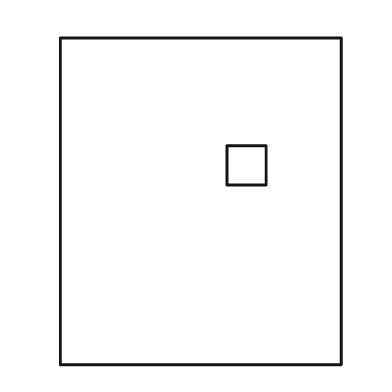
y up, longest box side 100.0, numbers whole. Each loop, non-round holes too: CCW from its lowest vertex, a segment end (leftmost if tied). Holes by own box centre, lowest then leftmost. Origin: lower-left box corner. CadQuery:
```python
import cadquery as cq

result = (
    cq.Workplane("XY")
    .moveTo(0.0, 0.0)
    .lineTo(86.0, 0.0)
    .lineTo(86.0, 100.0)
    .lineTo(0.0, 100.0)
    .close()
    .moveTo(51.0, 55.0)
    .lineTo(63.0, 55.0)
    .lineTo(63.0, 67.0)
    .lineTo(51.0, 67.0)
    .close()
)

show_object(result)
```